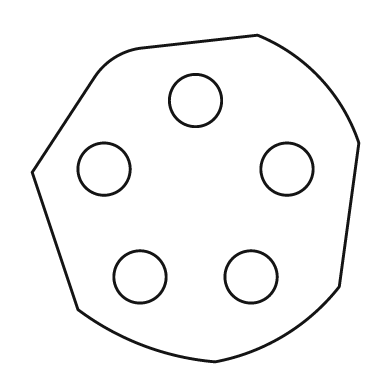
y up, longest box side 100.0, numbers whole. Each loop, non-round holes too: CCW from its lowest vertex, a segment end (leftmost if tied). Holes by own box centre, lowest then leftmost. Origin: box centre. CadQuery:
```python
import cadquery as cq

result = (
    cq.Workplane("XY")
    .moveTo(6.0, -50.0)
    .threePointArc((27.0, -42.0), (44.0, -27.0))
    .lineTo(50.0, 17.0)
    .threePointArc((38.0, 37.0), (19.0, 50.0))
    .lineTo(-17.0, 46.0)
    .threePointArc((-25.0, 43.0), (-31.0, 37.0))
    .lineTo(-50.0, 8.0)
    .lineTo(-36.0, -34.0)
    .threePointArc((-16.0, -45.0), (6.0, -50.0))
    .close()
    .moveTo(-17.0, -24.0)
    .circle(8.0)
    .moveTo(17.0, -24.0)
    .circle(8.0)
    .moveTo(-28.0, 9.0)
    .circle(8.0)
    .moveTo(28.0, 9.0)
    .circle(8.0)
    .moveTo(0.0, 30.0)
    .circle(8.0)
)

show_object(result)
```